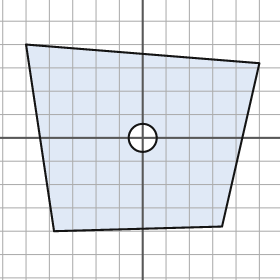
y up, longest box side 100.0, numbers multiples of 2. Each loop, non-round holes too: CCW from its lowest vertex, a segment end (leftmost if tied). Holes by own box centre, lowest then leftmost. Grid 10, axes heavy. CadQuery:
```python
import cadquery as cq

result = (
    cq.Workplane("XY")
    .moveTo(-38.0, -40.0)
    .lineTo(34.0, -38.0)
    .lineTo(50.0, 32.0)
    .lineTo(-50.0, 40.0)
    .close()
    .moveTo(0.0, 0.0)
    .circle(6.0)
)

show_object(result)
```